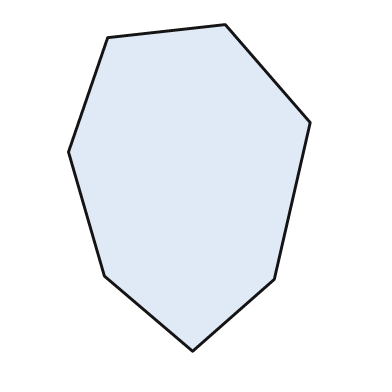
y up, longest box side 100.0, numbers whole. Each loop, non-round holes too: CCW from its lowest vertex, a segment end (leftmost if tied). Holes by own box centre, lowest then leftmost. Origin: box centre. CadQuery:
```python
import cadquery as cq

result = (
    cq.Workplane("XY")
    .moveTo(1.0, -50.0)
    .lineTo(26.0, -28.0)
    .lineTo(37.0, 20.0)
    .lineTo(11.0, 50.0)
    .lineTo(-25.0, 46.0)
    .lineTo(-37.0, 11.0)
    .lineTo(-26.0, -27.0)
    .close()
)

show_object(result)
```